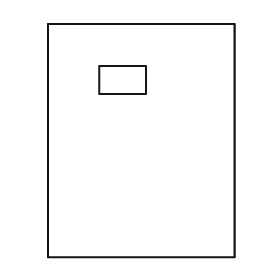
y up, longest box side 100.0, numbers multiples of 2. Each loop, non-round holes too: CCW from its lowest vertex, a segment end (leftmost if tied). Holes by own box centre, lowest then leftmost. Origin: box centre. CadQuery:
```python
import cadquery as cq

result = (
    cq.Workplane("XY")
    .moveTo(-40.0, -50.0)
    .lineTo(40.0, -50.0)
    .lineTo(40.0, 50.0)
    .lineTo(-40.0, 50.0)
    .close()
    .moveTo(-18.0, 20.0)
    .lineTo(2.0, 20.0)
    .lineTo(2.0, 32.0)
    .lineTo(-18.0, 32.0)
    .close()
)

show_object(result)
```